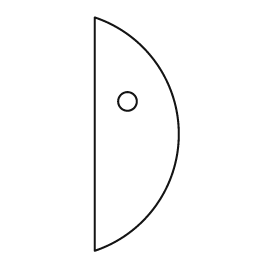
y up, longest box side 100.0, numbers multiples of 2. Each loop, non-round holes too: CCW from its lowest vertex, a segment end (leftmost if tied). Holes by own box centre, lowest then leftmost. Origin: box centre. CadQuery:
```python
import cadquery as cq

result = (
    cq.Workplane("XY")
    .moveTo(-18.0, -50.0)
    .threePointArc((18.0, 0.0), (-18.0, 50.0))
    .close()
    .moveTo(-4.0, 14.0)
    .circle(4.0)
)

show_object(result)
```